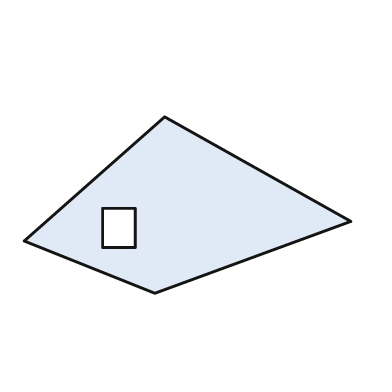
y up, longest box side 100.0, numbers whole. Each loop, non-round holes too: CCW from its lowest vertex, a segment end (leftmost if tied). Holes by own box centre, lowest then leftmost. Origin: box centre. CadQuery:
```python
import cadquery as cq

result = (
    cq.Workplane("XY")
    .moveTo(-10.0, -27.0)
    .lineTo(50.0, -5.0)
    .lineTo(-7.0, 27.0)
    .lineTo(-50.0, -11.0)
    .close()
    .moveTo(-26.0, -13.0)
    .lineTo(-16.0, -13.0)
    .lineTo(-16.0, -1.0)
    .lineTo(-26.0, -1.0)
    .close()
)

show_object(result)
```